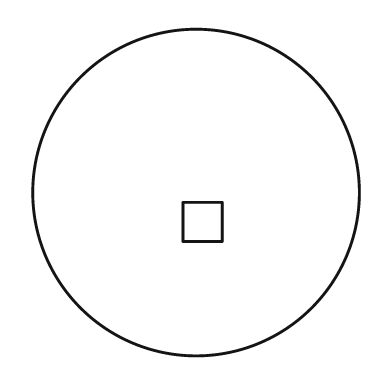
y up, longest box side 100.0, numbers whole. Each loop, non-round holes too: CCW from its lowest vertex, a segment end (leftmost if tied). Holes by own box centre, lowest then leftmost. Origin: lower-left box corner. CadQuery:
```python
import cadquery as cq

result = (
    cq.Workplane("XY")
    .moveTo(50.0, 50.0)
    .circle(50.0)
    .moveTo(46.0, 35.0)
    .lineTo(58.0, 35.0)
    .lineTo(58.0, 47.0)
    .lineTo(46.0, 47.0)
    .close()
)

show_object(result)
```